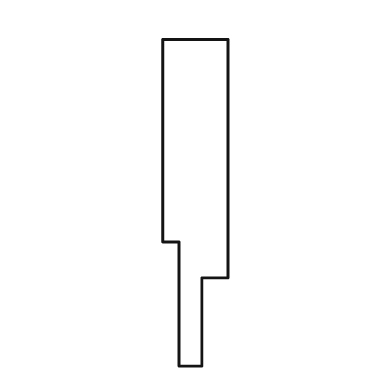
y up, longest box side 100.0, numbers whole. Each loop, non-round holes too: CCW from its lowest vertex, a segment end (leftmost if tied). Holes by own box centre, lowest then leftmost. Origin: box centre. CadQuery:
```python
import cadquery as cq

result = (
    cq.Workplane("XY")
    .moveTo(-5.0, -50.0)
    .lineTo(2.0, -50.0)
    .lineTo(2.0, -23.0)
    .lineTo(10.0, -23.0)
    .lineTo(10.0, 50.0)
    .lineTo(-10.0, 50.0)
    .lineTo(-10.0, -12.0)
    .lineTo(-5.0, -12.0)
    .close()
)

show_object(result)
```